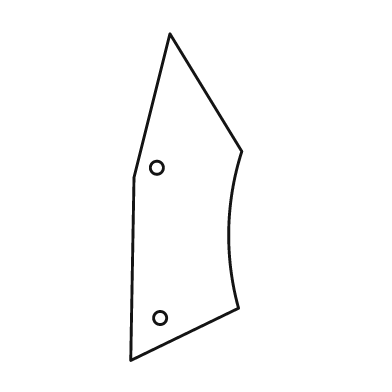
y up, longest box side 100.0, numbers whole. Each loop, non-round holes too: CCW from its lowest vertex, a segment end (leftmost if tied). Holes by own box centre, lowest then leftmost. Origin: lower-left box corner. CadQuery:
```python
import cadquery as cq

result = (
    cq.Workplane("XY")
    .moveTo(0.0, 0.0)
    .lineTo(33.0, 16.0)
    .threePointArc((30.0, 40.0), (34.0, 64.0))
    .lineTo(12.0, 100.0)
    .lineTo(1.0, 56.0)
    .close()
    .moveTo(9.0, 13.0)
    .circle(2.0)
    .moveTo(8.0, 59.0)
    .circle(2.0)
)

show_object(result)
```